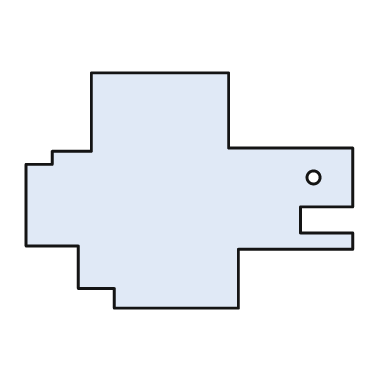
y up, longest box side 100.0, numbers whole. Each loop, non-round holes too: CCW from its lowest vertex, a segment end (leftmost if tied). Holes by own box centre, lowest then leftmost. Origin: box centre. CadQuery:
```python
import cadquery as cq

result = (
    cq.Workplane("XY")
    .moveTo(-23.0, -36.0)
    .lineTo(15.0, -36.0)
    .lineTo(15.0, -18.0)
    .lineTo(50.0, -18.0)
    .lineTo(50.0, -13.0)
    .lineTo(34.0, -13.0)
    .lineTo(34.0, -5.0)
    .lineTo(50.0, -5.0)
    .lineTo(50.0, 13.0)
    .lineTo(12.0, 13.0)
    .lineTo(12.0, 36.0)
    .lineTo(-30.0, 36.0)
    .lineTo(-30.0, 12.0)
    .lineTo(-42.0, 12.0)
    .lineTo(-42.0, 8.0)
    .lineTo(-50.0, 8.0)
    .lineTo(-50.0, -17.0)
    .lineTo(-34.0, -17.0)
    .lineTo(-34.0, -30.0)
    .lineTo(-23.0, -30.0)
    .close()
    .moveTo(38.0, 4.0)
    .circle(2.0)
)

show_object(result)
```